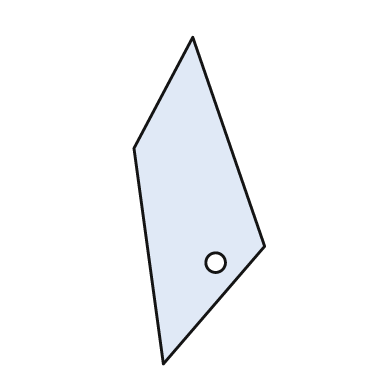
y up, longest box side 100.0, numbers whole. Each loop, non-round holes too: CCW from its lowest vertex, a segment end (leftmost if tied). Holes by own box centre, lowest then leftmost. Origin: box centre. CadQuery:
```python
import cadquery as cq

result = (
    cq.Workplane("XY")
    .moveTo(-11.0, -50.0)
    .lineTo(20.0, -14.0)
    .lineTo(-2.0, 50.0)
    .lineTo(-20.0, 16.0)
    .close()
    .moveTo(5.0, -19.0)
    .circle(3.0)
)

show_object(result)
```